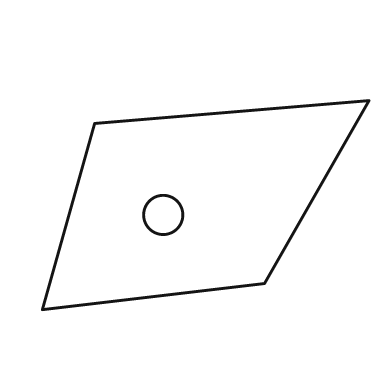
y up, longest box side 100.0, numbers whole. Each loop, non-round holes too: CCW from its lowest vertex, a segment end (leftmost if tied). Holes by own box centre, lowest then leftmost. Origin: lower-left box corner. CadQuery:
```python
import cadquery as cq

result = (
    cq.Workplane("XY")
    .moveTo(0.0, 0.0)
    .lineTo(68.0, 8.0)
    .lineTo(100.0, 64.0)
    .lineTo(16.0, 57.0)
    .close()
    .moveTo(37.0, 29.0)
    .circle(6.0)
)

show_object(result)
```